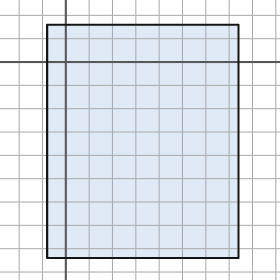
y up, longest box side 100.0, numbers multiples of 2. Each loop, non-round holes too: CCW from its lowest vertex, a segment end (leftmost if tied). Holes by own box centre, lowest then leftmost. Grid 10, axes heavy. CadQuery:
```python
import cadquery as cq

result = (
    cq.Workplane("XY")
    .moveTo(-8.0, -84.0)
    .lineTo(74.0, -84.0)
    .lineTo(74.0, 16.0)
    .lineTo(-8.0, 16.0)
    .close()
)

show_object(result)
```